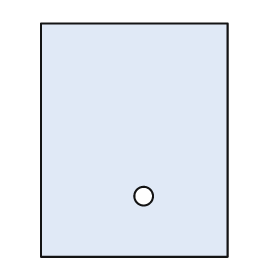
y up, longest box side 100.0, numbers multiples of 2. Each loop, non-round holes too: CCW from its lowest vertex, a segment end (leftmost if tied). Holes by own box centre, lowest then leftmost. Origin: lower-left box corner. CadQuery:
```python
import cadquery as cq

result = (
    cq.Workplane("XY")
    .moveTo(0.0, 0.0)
    .lineTo(80.0, 0.0)
    .lineTo(80.0, 100.0)
    .lineTo(0.0, 100.0)
    .close()
    .moveTo(44.0, 26.0)
    .circle(4.0)
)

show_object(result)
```